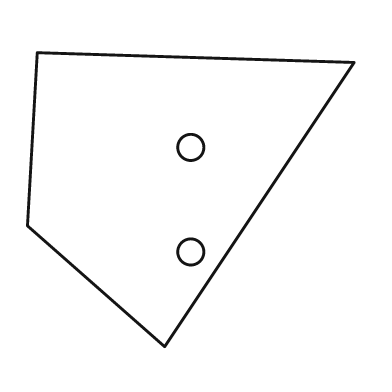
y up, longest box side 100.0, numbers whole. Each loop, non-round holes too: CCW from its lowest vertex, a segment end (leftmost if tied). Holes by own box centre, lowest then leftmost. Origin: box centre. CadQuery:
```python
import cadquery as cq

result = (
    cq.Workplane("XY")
    .moveTo(-8.0, -45.0)
    .lineTo(50.0, 42.0)
    .lineTo(-47.0, 45.0)
    .lineTo(-50.0, -8.0)
    .close()
    .moveTo(0.0, -16.0)
    .circle(4.0)
    .moveTo(0.0, 16.0)
    .circle(4.0)
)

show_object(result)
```